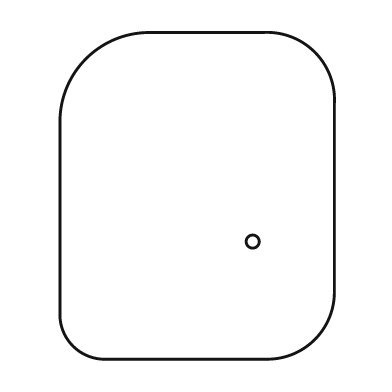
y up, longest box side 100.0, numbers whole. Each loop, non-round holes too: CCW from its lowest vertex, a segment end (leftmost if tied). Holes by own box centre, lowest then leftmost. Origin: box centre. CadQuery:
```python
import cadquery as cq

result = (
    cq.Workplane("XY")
    .moveTo(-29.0, -50.0)
    .lineTo(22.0, -50.0)
    .threePointArc((36.0, -44.0), (42.0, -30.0))
    .lineTo(42.0, 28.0)
    .threePointArc((36.0, 44.0), (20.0, 50.0))
    .lineTo(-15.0, 50.0)
    .threePointArc((-34.0, 42.0), (-42.0, 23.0))
    .lineTo(-42.0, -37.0)
    .threePointArc((-38.0, -46.0), (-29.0, -50.0))
    .close()
    .moveTo(17.0, -14.0)
    .circle(2.0)
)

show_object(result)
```